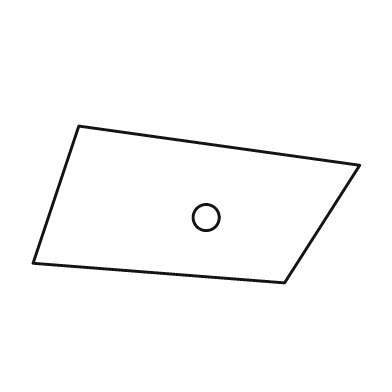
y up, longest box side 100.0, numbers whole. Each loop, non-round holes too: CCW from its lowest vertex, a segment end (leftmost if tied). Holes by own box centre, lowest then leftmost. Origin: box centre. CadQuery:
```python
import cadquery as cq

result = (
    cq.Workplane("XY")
    .moveTo(27.0, -24.0)
    .lineTo(50.0, 12.0)
    .lineTo(-36.0, 24.0)
    .lineTo(-50.0, -18.0)
    .close()
    .moveTo(3.0, -4.0)
    .circle(4.0)
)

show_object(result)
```